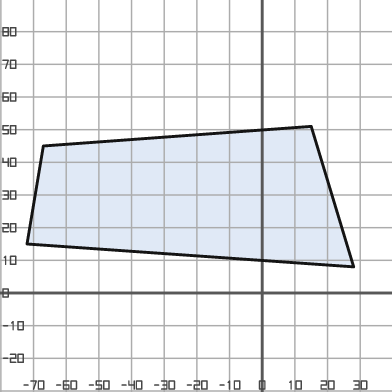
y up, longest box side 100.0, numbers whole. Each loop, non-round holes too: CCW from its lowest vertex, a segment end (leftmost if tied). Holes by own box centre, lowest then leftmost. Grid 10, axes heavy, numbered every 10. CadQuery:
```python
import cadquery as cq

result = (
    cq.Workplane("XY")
    .moveTo(28.0, 8.0)
    .lineTo(15.0, 51.0)
    .lineTo(-67.0, 45.0)
    .lineTo(-72.0, 15.0)
    .close()
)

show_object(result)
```